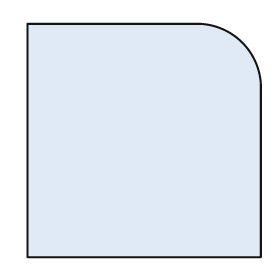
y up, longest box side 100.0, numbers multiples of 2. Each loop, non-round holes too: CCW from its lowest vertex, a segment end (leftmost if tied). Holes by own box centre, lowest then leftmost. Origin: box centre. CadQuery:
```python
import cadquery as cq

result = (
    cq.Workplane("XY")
    .moveTo(-50.0, -50.0)
    .lineTo(50.0, -50.0)
    .lineTo(50.0, 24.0)
    .threePointArc((42.0, 42.0), (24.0, 50.0))
    .lineTo(-50.0, 50.0)
    .close()
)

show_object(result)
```